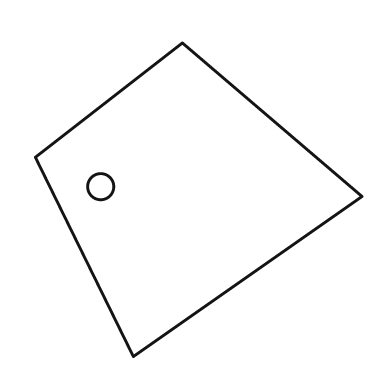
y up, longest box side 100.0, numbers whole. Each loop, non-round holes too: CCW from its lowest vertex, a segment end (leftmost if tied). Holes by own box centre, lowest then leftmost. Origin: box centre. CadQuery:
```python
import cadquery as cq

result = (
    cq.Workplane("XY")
    .moveTo(-20.0, -48.0)
    .lineTo(50.0, 1.0)
    .lineTo(-5.0, 48.0)
    .lineTo(-50.0, 13.0)
    .close()
    .moveTo(-30.0, 4.0)
    .circle(4.0)
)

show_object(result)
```